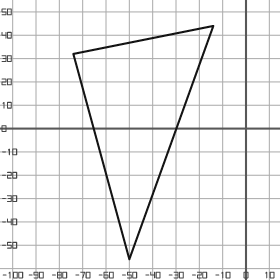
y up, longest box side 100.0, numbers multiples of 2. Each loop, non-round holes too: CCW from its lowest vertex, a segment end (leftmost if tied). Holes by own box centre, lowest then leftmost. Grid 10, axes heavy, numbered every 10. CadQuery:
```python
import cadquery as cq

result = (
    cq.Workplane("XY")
    .moveTo(-50.0, -56.0)
    .lineTo(-14.0, 44.0)
    .lineTo(-74.0, 32.0)
    .close()
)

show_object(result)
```